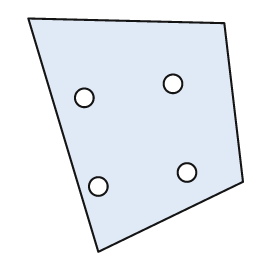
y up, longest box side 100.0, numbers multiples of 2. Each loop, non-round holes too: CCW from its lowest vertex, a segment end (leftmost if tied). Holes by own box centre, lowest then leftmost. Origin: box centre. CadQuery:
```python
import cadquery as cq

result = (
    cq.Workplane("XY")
    .moveTo(-16.0, -50.0)
    .lineTo(46.0, -20.0)
    .lineTo(38.0, 48.0)
    .lineTo(-46.0, 50.0)
    .close()
    .moveTo(-16.0, -22.0)
    .circle(4.0)
    .moveTo(22.0, -16.0)
    .circle(4.0)
    .moveTo(-22.0, 16.0)
    .circle(4.0)
    .moveTo(16.0, 22.0)
    .circle(4.0)
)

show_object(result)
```